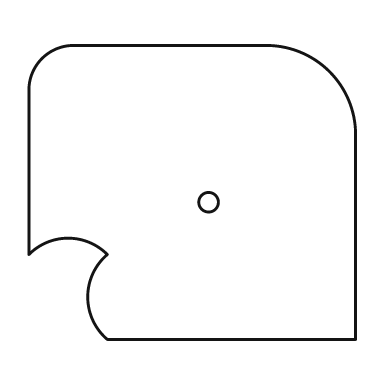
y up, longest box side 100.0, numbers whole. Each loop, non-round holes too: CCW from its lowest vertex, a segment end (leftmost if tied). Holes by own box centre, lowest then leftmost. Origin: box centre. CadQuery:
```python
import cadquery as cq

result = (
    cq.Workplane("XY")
    .moveTo(-26.0, -45.0)
    .lineTo(50.0, -45.0)
    .lineTo(50.0, 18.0)
    .threePointArc((42.0, 37.0), (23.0, 45.0))
    .lineTo(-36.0, 45.0)
    .threePointArc((-46.0, 41.0), (-50.0, 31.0))
    .lineTo(-50.0, -19.0)
    .threePointArc((-38.0, -14.0), (-26.0, -19.0))
    .threePointArc((-32.0, -32.0), (-26.0, -45.0))
    .close()
    .moveTo(5.0, -3.0)
    .circle(3.0)
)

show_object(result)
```